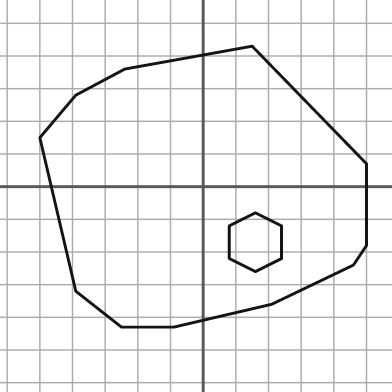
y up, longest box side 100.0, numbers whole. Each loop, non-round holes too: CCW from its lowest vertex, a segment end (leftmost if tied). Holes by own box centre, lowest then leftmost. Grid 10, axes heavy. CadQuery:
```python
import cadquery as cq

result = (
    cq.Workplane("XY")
    .moveTo(-25.0, -43.0)
    .lineTo(-9.0, -43.0)
    .lineTo(21.0, -36.0)
    .lineTo(46.0, -24.0)
    .lineTo(50.0, -18.0)
    .lineTo(50.0, 7.0)
    .lineTo(15.0, 43.0)
    .lineTo(-24.0, 36.0)
    .lineTo(-39.0, 28.0)
    .lineTo(-50.0, 15.0)
    .lineTo(-39.0, -32.0)
    .close()
    .moveTo(16.0, -26.0)
    .lineTo(24.0, -22.0)
    .lineTo(24.0, -12.0)
    .lineTo(16.0, -8.0)
    .lineTo(8.0, -12.0)
    .lineTo(8.0, -22.0)
    .close()
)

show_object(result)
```